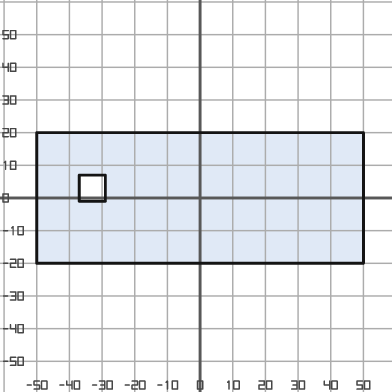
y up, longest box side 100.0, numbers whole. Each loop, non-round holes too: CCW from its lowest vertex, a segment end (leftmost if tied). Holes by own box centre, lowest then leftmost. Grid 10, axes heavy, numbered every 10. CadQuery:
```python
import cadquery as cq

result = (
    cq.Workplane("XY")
    .moveTo(-50.0, -20.0)
    .lineTo(50.0, -20.0)
    .lineTo(50.0, 20.0)
    .lineTo(-50.0, 20.0)
    .close()
    .moveTo(-37.0, -1.0)
    .lineTo(-29.0, -1.0)
    .lineTo(-29.0, 7.0)
    .lineTo(-37.0, 7.0)
    .close()
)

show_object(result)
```